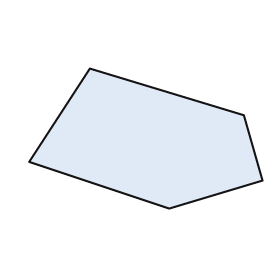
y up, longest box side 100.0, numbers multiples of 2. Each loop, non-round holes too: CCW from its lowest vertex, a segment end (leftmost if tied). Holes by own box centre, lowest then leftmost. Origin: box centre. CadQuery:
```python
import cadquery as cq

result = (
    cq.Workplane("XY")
    .moveTo(10.0, -30.0)
    .lineTo(50.0, -18.0)
    .lineTo(42.0, 10.0)
    .lineTo(-24.0, 30.0)
    .lineTo(-50.0, -10.0)
    .close()
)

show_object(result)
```